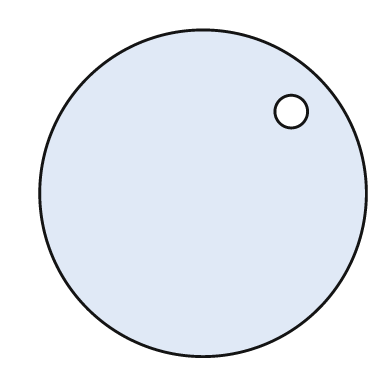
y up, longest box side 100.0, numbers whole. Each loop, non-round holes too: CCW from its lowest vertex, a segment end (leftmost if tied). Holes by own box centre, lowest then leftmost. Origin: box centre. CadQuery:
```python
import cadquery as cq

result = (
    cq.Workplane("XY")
    .moveTo(0.0, 0.0)
    .circle(50.0)
    .moveTo(27.0, 25.0)
    .circle(5.0)
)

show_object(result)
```